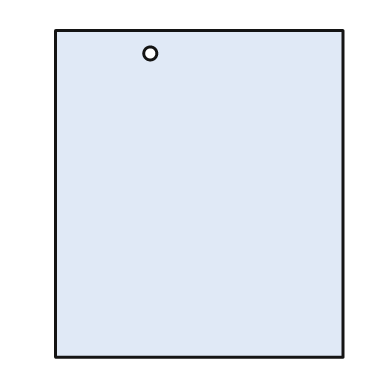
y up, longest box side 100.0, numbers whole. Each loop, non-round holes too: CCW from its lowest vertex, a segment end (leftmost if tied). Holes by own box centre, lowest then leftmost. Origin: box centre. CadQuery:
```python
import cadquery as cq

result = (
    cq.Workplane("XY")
    .moveTo(-44.0, -50.0)
    .lineTo(44.0, -50.0)
    .lineTo(44.0, 50.0)
    .lineTo(-44.0, 50.0)
    .close()
    .moveTo(-15.0, 43.0)
    .circle(2.0)
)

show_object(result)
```